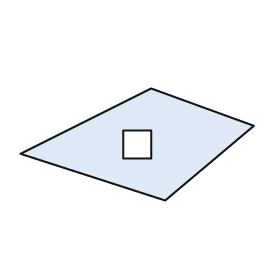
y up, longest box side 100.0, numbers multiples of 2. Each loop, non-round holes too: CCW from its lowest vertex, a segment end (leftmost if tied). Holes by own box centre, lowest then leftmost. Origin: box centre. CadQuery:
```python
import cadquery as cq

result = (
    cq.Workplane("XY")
    .moveTo(12.0, -24.0)
    .lineTo(50.0, 8.0)
    .lineTo(6.0, 24.0)
    .lineTo(-50.0, -4.0)
    .close()
    .moveTo(-6.0, -6.0)
    .lineTo(6.0, -6.0)
    .lineTo(6.0, 6.0)
    .lineTo(-6.0, 6.0)
    .close()
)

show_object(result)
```